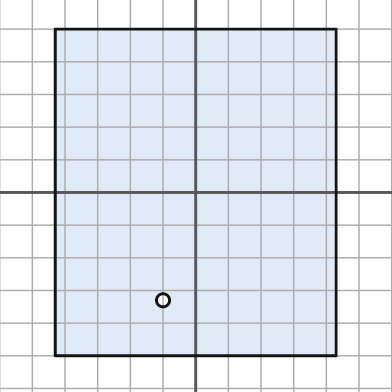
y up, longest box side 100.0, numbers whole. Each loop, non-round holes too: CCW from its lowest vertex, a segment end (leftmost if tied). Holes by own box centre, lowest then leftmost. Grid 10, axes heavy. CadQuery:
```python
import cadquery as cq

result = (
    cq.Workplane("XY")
    .moveTo(-43.0, -50.0)
    .lineTo(43.0, -50.0)
    .lineTo(43.0, 50.0)
    .lineTo(-43.0, 50.0)
    .close()
    .moveTo(-10.0, -33.0)
    .circle(2.0)
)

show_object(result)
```